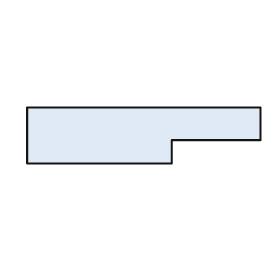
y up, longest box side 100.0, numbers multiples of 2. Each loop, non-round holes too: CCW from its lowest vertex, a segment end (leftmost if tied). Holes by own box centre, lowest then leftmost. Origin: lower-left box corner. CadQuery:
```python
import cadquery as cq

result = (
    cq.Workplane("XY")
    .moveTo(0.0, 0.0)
    .lineTo(62.0, 0.0)
    .lineTo(62.0, 10.0)
    .lineTo(100.0, 10.0)
    .lineTo(100.0, 24.0)
    .lineTo(0.0, 24.0)
    .close()
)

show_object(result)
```